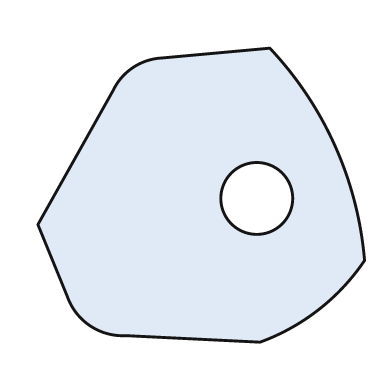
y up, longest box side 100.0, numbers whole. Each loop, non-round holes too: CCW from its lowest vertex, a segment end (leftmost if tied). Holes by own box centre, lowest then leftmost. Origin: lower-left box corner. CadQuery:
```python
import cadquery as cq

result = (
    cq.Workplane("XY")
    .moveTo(68.0, 0.0)
    .threePointArc((86.0, 10.0), (100.0, 25.0))
    .threePointArc((91.0, 60.0), (71.0, 90.0))
    .lineTo(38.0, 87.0)
    .threePointArc((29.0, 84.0), (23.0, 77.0))
    .lineTo(0.0, 36.0)
    .lineTo(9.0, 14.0)
    .threePointArc((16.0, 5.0), (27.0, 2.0))
    .close()
    .moveTo(67.0, 44.0)
    .circle(11.0)
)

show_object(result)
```